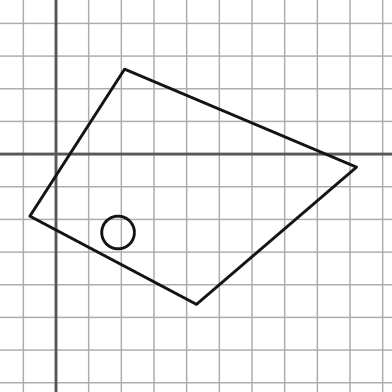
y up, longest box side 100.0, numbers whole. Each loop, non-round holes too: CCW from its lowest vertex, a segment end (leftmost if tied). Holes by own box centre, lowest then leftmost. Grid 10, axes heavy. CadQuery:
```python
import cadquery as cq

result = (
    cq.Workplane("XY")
    .moveTo(43.0, -46.0)
    .lineTo(92.0, -4.0)
    .lineTo(21.0, 26.0)
    .lineTo(-8.0, -19.0)
    .close()
    .moveTo(19.0, -24.0)
    .circle(5.0)
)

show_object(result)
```